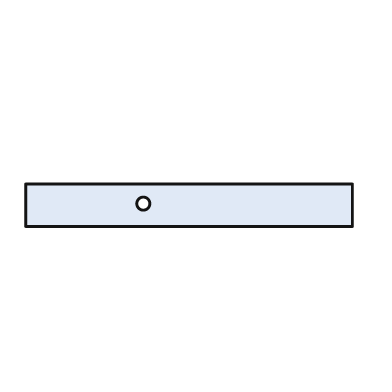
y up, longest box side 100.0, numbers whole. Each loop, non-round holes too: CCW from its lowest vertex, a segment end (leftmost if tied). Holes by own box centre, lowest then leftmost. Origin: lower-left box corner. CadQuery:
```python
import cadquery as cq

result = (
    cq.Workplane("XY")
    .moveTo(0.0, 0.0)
    .lineTo(100.0, 0.0)
    .lineTo(100.0, 13.0)
    .lineTo(0.0, 13.0)
    .close()
    .moveTo(36.0, 7.0)
    .circle(2.0)
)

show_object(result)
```